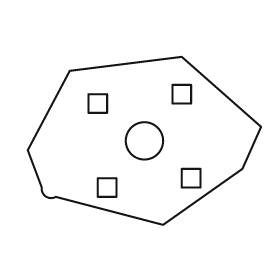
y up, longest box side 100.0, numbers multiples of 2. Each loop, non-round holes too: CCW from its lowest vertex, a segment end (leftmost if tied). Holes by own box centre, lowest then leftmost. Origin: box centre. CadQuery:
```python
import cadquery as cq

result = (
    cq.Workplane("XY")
    .moveTo(8.0, -36.0)
    .lineTo(42.0, -12.0)
    .lineTo(50.0, 6.0)
    .lineTo(16.0, 36.0)
    .lineTo(-32.0, 30.0)
    .lineTo(-50.0, -4.0)
    .lineTo(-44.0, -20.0)
    .threePointArc((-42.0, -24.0), (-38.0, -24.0))
    .close()
    .moveTo(-20.0, -24.0)
    .lineTo(-12.0, -24.0)
    .lineTo(-12.0, -16.0)
    .lineTo(-20.0, -16.0)
    .close()
    .moveTo(16.0, -20.0)
    .lineTo(24.0, -20.0)
    .lineTo(24.0, -12.0)
    .lineTo(16.0, -12.0)
    .close()
    .moveTo(0.0, 0.0)
    .circle(8.0)
    .moveTo(-24.0, 12.0)
    .lineTo(-16.0, 12.0)
    .lineTo(-16.0, 20.0)
    .lineTo(-24.0, 20.0)
    .close()
    .moveTo(12.0, 16.0)
    .lineTo(20.0, 16.0)
    .lineTo(20.0, 24.0)
    .lineTo(12.0, 24.0)
    .close()
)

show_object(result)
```